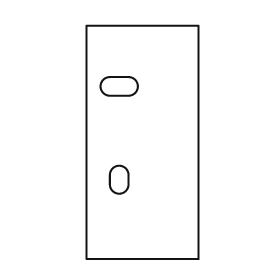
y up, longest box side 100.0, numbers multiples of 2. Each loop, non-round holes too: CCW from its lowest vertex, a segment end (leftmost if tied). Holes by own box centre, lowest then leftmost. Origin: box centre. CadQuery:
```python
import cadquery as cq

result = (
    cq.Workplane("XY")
    .moveTo(-24.0, -50.0)
    .lineTo(24.0, -50.0)
    .lineTo(24.0, 50.0)
    .lineTo(-24.0, 50.0)
    .close()
    .moveTo(-14.0, -18.0)
    .threePointArc((-10.0, -22.0), (-6.0, -18.0))
    .lineTo(-6.0, -14.0)
    .threePointArc((-10.0, -10.0), (-14.0, -14.0))
    .close()
    .moveTo(-14.0, 20.0)
    .lineTo(-6.0, 20.0)
    .threePointArc((-2.0, 24.0), (-6.0, 28.0))
    .lineTo(-14.0, 28.0)
    .threePointArc((-18.0, 24.0), (-14.0, 20.0))
    .close()
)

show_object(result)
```